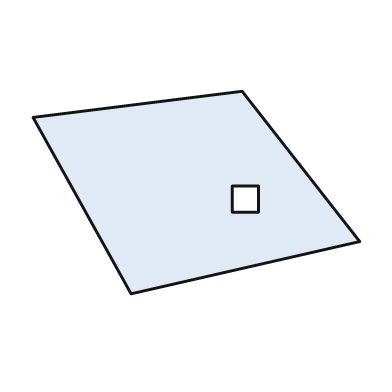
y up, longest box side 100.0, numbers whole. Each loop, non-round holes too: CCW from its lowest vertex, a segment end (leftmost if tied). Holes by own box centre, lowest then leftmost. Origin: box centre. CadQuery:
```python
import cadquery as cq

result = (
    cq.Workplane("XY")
    .moveTo(-20.0, -31.0)
    .lineTo(50.0, -15.0)
    .lineTo(14.0, 31.0)
    .lineTo(-50.0, 23.0)
    .close()
    .moveTo(11.0, -6.0)
    .lineTo(19.0, -6.0)
    .lineTo(19.0, 2.0)
    .lineTo(11.0, 2.0)
    .close()
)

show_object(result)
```